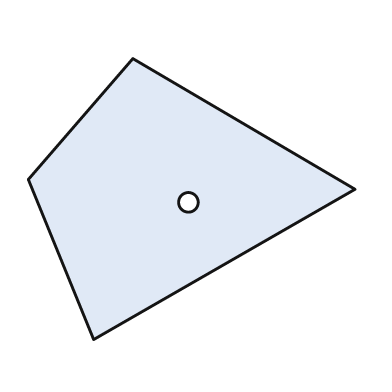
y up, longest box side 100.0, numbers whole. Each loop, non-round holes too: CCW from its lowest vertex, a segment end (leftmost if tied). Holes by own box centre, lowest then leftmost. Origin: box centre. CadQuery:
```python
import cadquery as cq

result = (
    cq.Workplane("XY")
    .moveTo(-30.0, -43.0)
    .lineTo(50.0, 3.0)
    .lineTo(-18.0, 43.0)
    .lineTo(-50.0, 6.0)
    .close()
    .moveTo(-1.0, -1.0)
    .circle(3.0)
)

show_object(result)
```